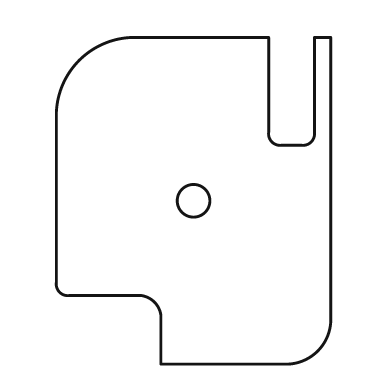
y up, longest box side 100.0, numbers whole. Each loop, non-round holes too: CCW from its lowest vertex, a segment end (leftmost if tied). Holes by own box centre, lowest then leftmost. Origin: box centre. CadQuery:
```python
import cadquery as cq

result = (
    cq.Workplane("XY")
    .moveTo(-10.0, -50.0)
    .lineTo(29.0, -50.0)
    .threePointArc((38.0, -46.0), (42.0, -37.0))
    .lineTo(42.0, 50.0)
    .lineTo(37.0, 50.0)
    .lineTo(37.0, 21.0)
    .threePointArc((36.0, 18.0), (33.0, 17.0))
    .lineTo(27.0, 17.0)
    .threePointArc((24.0, 18.0), (23.0, 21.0))
    .lineTo(23.0, 50.0)
    .lineTo(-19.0, 50.0)
    .threePointArc((-35.0, 43.0), (-42.0, 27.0))
    .lineTo(-42.0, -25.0)
    .threePointArc((-41.0, -28.0), (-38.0, -29.0))
    .lineTo(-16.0, -29.0)
    .threePointArc((-12.0, -31.0), (-10.0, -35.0))
    .close()
    .moveTo(0.0, 0.0)
    .circle(5.0)
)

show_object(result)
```